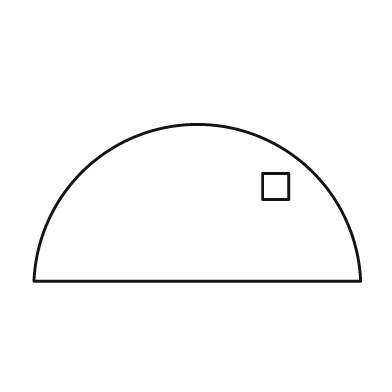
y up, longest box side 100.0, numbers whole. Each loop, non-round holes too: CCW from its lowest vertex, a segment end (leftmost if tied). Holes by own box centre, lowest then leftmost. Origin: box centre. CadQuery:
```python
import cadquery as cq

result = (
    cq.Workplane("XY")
    .moveTo(-50.0, -24.0)
    .lineTo(50.0, -24.0)
    .threePointArc((0.0, 24.0), (-50.0, -24.0))
    .close()
    .moveTo(20.0, 1.0)
    .lineTo(28.0, 1.0)
    .lineTo(28.0, 9.0)
    .lineTo(20.0, 9.0)
    .close()
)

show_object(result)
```